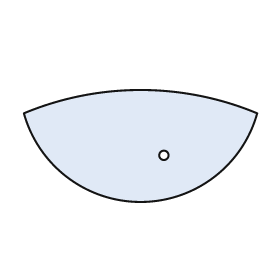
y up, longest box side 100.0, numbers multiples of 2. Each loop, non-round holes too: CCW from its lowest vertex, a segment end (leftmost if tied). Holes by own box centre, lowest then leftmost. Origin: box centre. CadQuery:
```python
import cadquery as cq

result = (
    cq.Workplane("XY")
    .moveTo(-50.0, 14.0)
    .threePointArc((0.0, -24.0), (50.0, 14.0))
    .threePointArc((0.0, 24.0), (-50.0, 14.0))
    .close()
    .moveTo(10.0, -4.0)
    .circle(2.0)
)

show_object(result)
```